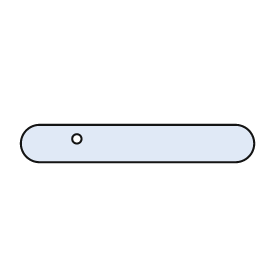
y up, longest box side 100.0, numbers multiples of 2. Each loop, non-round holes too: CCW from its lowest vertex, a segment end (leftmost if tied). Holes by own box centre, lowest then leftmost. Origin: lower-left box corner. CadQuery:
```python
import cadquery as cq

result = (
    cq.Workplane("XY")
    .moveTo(8.0, 0.0)
    .lineTo(92.0, 0.0)
    .threePointArc((100.0, 8.0), (92.0, 16.0))
    .lineTo(8.0, 16.0)
    .threePointArc((0.0, 8.0), (8.0, 0.0))
    .close()
    .moveTo(24.0, 10.0)
    .circle(2.0)
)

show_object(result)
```